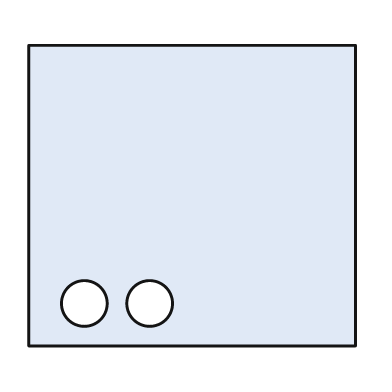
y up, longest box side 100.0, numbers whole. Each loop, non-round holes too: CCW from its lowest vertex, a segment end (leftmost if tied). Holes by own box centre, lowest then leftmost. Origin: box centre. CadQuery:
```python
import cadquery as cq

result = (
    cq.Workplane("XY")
    .moveTo(-50.0, -46.0)
    .lineTo(50.0, -46.0)
    .lineTo(50.0, 46.0)
    .lineTo(-50.0, 46.0)
    .close()
    .moveTo(-33.0, -33.0)
    .circle(7.0)
    .moveTo(-13.0, -33.0)
    .circle(7.0)
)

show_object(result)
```